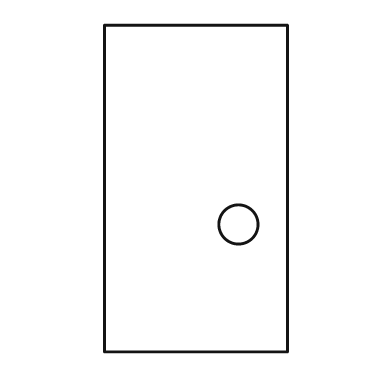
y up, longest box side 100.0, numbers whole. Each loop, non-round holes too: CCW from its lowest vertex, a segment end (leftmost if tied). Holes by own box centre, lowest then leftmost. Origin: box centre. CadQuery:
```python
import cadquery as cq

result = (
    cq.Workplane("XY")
    .moveTo(-28.0, -50.0)
    .lineTo(28.0, -50.0)
    .lineTo(28.0, 50.0)
    .lineTo(-28.0, 50.0)
    .close()
    .moveTo(13.0, -11.0)
    .circle(6.0)
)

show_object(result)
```